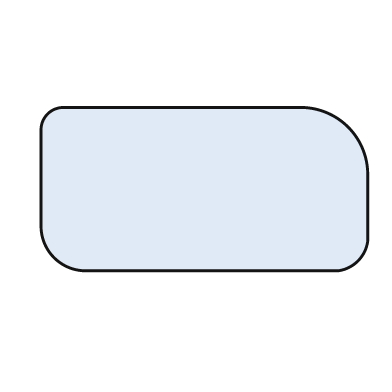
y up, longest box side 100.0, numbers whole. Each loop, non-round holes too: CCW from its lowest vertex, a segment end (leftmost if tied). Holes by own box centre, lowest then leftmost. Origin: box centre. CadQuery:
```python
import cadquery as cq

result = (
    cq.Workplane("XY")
    .moveTo(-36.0, -25.0)
    .lineTo(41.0, -25.0)
    .threePointArc((47.0, -22.0), (50.0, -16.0))
    .lineTo(50.0, 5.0)
    .threePointArc((44.0, 19.0), (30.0, 25.0))
    .lineTo(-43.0, 25.0)
    .threePointArc((-48.0, 23.0), (-50.0, 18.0))
    .lineTo(-50.0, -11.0)
    .threePointArc((-46.0, -21.0), (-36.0, -25.0))
    .close()
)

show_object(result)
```